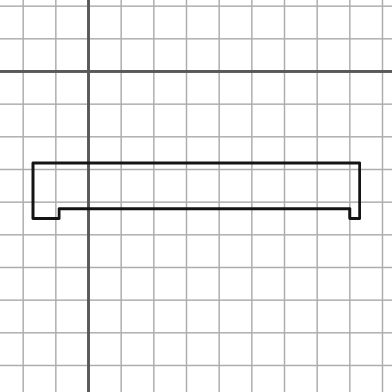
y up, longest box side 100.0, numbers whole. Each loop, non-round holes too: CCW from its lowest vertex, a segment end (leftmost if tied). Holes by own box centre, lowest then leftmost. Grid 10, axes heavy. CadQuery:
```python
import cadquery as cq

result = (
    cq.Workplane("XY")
    .moveTo(-17.0, -45.0)
    .lineTo(-9.0, -45.0)
    .lineTo(-9.0, -42.0)
    .lineTo(80.0, -42.0)
    .lineTo(80.0, -45.0)
    .lineTo(83.0, -45.0)
    .lineTo(83.0, -28.0)
    .lineTo(-17.0, -28.0)
    .close()
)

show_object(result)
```